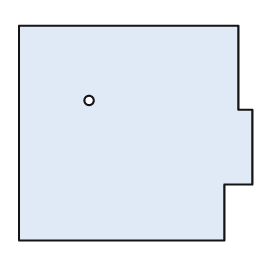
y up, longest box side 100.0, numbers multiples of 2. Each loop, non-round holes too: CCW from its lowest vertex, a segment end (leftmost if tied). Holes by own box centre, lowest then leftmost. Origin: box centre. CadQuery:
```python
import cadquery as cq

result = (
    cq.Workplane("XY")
    .moveTo(-50.0, -46.0)
    .lineTo(38.0, -46.0)
    .lineTo(38.0, -22.0)
    .lineTo(50.0, -22.0)
    .lineTo(50.0, 10.0)
    .lineTo(44.0, 10.0)
    .lineTo(44.0, 46.0)
    .lineTo(-50.0, 46.0)
    .close()
    .moveTo(-20.0, 14.0)
    .circle(2.0)
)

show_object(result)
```